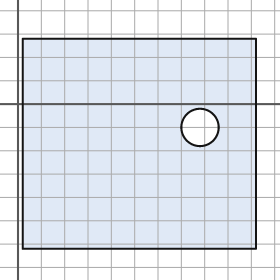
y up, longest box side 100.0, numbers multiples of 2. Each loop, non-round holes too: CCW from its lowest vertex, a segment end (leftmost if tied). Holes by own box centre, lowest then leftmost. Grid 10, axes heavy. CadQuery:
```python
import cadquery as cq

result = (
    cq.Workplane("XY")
    .moveTo(2.0, -62.0)
    .lineTo(102.0, -62.0)
    .lineTo(102.0, 28.0)
    .lineTo(2.0, 28.0)
    .close()
    .moveTo(78.0, -10.0)
    .circle(8.0)
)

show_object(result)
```